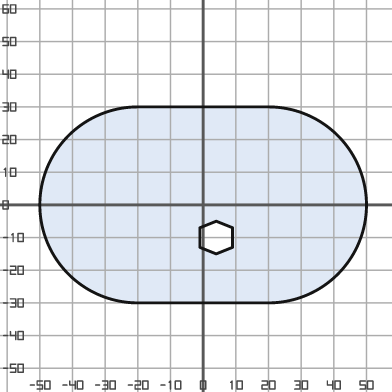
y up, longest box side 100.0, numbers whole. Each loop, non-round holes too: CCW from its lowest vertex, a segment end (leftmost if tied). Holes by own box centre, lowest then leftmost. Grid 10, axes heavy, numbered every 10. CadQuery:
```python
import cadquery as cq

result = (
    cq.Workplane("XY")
    .moveTo(-20.0, -30.0)
    .lineTo(20.0, -30.0)
    .threePointArc((50.0, 0.0), (20.0, 30.0))
    .lineTo(-20.0, 30.0)
    .threePointArc((-50.0, 0.0), (-20.0, -30.0))
    .close()
    .moveTo(4.0, -15.0)
    .lineTo(9.0, -13.0)
    .lineTo(9.0, -7.0)
    .lineTo(4.0, -5.0)
    .lineTo(-1.0, -7.0)
    .lineTo(-1.0, -13.0)
    .close()
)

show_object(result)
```